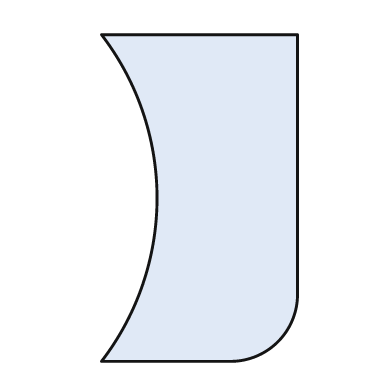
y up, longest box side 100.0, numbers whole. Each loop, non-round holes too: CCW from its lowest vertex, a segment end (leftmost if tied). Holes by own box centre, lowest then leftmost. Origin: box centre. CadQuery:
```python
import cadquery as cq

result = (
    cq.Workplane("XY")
    .moveTo(-30.0, -50.0)
    .lineTo(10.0, -50.0)
    .threePointArc((24.0, -44.0), (30.0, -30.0))
    .lineTo(30.0, 50.0)
    .lineTo(-30.0, 50.0)
    .threePointArc((-13.0, 0.0), (-30.0, -50.0))
    .close()
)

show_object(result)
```